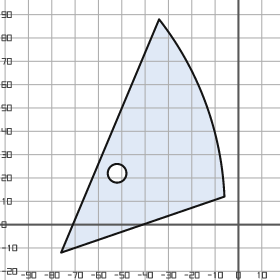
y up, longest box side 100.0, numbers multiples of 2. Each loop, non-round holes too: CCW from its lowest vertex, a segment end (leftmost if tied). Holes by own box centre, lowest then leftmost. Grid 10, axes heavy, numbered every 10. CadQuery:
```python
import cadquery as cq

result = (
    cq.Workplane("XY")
    .moveTo(-76.0, -12.0)
    .lineTo(-6.0, 12.0)
    .threePointArc((-14.0, 52.0), (-34.0, 88.0))
    .close()
    .moveTo(-52.0, 22.0)
    .circle(4.0)
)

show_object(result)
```